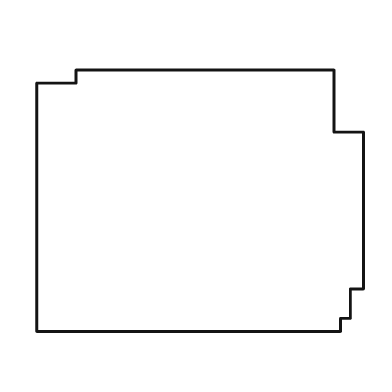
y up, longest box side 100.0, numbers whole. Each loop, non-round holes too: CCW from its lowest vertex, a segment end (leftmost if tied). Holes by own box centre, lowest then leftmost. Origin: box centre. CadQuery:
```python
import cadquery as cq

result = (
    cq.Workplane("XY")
    .moveTo(-50.0, -40.0)
    .lineTo(43.0, -40.0)
    .lineTo(43.0, -36.0)
    .lineTo(46.0, -36.0)
    .lineTo(46.0, -27.0)
    .lineTo(50.0, -27.0)
    .lineTo(50.0, 21.0)
    .lineTo(41.0, 21.0)
    .lineTo(41.0, 40.0)
    .lineTo(-38.0, 40.0)
    .lineTo(-38.0, 36.0)
    .lineTo(-50.0, 36.0)
    .close()
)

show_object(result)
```